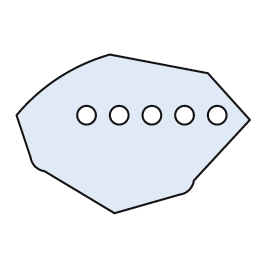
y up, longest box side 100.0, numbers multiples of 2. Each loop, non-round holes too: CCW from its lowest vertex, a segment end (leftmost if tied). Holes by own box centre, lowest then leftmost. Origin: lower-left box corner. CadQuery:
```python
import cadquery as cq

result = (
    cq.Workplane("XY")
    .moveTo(42.0, 0.0)
    .lineTo(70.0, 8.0)
    .threePointArc((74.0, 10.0), (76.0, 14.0))
    .lineTo(100.0, 40.0)
    .lineTo(82.0, 60.0)
    .lineTo(40.0, 68.0)
    .threePointArc((18.0, 58.0), (0.0, 42.0))
    .lineTo(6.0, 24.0)
    .threePointArc((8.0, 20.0), (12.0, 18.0))
    .close()
    .moveTo(30.0, 42.0)
    .circle(4.0)
    .moveTo(44.0, 42.0)
    .circle(4.0)
    .moveTo(58.0, 42.0)
    .circle(4.0)
    .moveTo(72.0, 42.0)
    .circle(4.0)
    .moveTo(86.0, 42.0)
    .circle(4.0)
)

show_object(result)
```